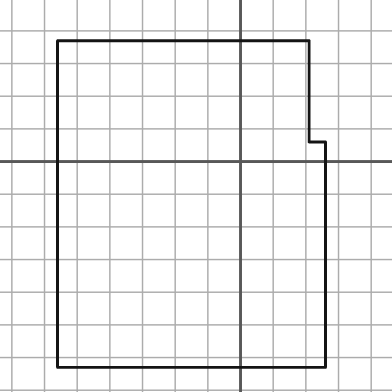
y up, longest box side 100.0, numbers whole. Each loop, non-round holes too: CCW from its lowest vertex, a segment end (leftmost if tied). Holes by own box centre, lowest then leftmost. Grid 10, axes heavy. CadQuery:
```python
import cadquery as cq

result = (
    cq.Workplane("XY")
    .moveTo(-56.0, -63.0)
    .lineTo(26.0, -63.0)
    .lineTo(26.0, 6.0)
    .lineTo(21.0, 6.0)
    .lineTo(21.0, 37.0)
    .lineTo(-56.0, 37.0)
    .close()
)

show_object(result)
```